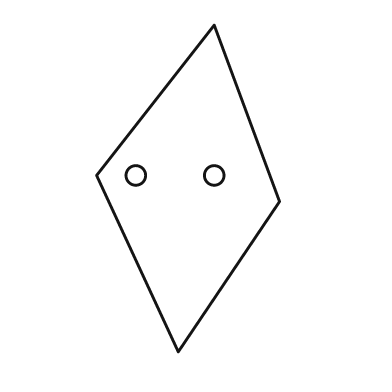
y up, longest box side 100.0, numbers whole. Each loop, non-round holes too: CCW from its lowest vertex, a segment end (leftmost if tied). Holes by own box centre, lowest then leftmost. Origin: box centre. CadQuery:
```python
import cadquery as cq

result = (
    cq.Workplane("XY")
    .moveTo(-3.0, -50.0)
    .lineTo(28.0, -4.0)
    .lineTo(8.0, 50.0)
    .lineTo(-28.0, 4.0)
    .close()
    .moveTo(-16.0, 4.0)
    .circle(3.0)
    .moveTo(8.0, 4.0)
    .circle(3.0)
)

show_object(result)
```